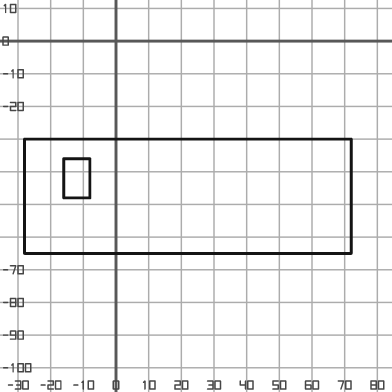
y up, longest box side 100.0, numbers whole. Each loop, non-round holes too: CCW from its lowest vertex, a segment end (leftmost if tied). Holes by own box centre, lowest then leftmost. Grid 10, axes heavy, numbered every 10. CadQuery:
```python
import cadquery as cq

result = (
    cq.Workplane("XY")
    .moveTo(-28.0, -65.0)
    .lineTo(72.0, -65.0)
    .lineTo(72.0, -30.0)
    .lineTo(-28.0, -30.0)
    .close()
    .moveTo(-16.0, -48.0)
    .lineTo(-8.0, -48.0)
    .lineTo(-8.0, -36.0)
    .lineTo(-16.0, -36.0)
    .close()
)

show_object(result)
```